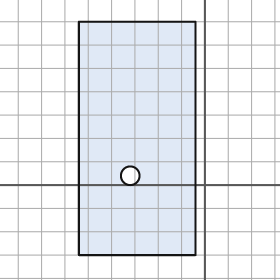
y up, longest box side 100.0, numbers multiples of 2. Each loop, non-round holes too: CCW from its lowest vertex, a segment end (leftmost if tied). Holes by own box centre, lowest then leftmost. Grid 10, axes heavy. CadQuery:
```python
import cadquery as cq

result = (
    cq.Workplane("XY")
    .moveTo(-54.0, -30.0)
    .lineTo(-4.0, -30.0)
    .lineTo(-4.0, 70.0)
    .lineTo(-54.0, 70.0)
    .close()
    .moveTo(-32.0, 4.0)
    .circle(4.0)
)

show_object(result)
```